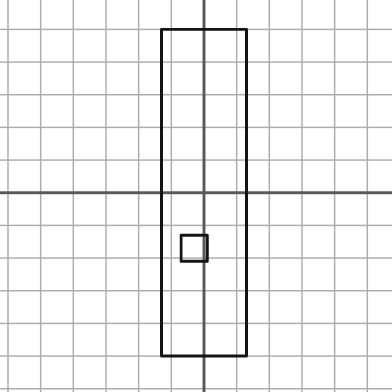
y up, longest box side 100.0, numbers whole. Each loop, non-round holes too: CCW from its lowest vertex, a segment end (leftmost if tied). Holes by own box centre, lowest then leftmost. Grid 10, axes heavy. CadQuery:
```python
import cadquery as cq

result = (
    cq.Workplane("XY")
    .moveTo(-13.0, -50.0)
    .lineTo(13.0, -50.0)
    .lineTo(13.0, 50.0)
    .lineTo(-13.0, 50.0)
    .close()
    .moveTo(-7.0, -21.0)
    .lineTo(1.0, -21.0)
    .lineTo(1.0, -13.0)
    .lineTo(-7.0, -13.0)
    .close()
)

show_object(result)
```